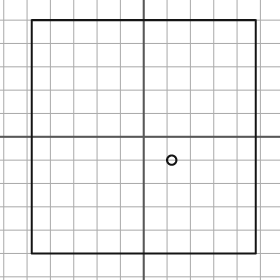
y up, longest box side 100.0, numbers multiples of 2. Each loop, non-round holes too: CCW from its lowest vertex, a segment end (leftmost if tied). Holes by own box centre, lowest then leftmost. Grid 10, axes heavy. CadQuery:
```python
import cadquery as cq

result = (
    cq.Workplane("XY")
    .moveTo(-48.0, -50.0)
    .lineTo(48.0, -50.0)
    .lineTo(48.0, 50.0)
    .lineTo(-48.0, 50.0)
    .close()
    .moveTo(12.0, -10.0)
    .circle(2.0)
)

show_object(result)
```